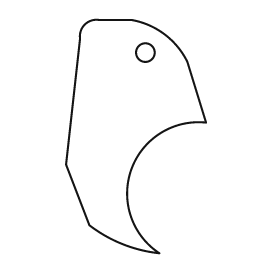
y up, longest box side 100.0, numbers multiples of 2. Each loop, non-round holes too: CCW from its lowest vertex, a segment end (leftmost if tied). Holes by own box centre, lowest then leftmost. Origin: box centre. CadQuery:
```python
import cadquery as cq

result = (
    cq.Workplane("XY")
    .moveTo(10.0, -50.0)
    .threePointArc((-2.0, -14.0), (30.0, 6.0))
    .lineTo(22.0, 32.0)
    .threePointArc((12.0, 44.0), (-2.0, 50.0))
    .lineTo(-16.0, 50.0)
    .threePointArc((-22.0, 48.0), (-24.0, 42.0))
    .lineTo(-30.0, -12.0)
    .lineTo(-20.0, -38.0)
    .threePointArc((-6.0, -46.0), (10.0, -50.0))
    .close()
    .moveTo(4.0, 36.0)
    .circle(4.0)
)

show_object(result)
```